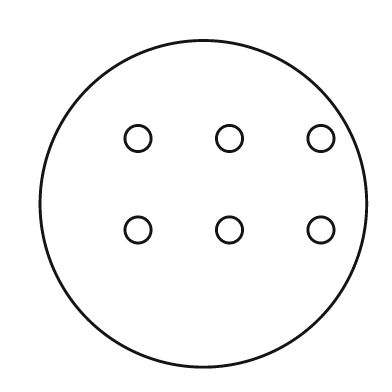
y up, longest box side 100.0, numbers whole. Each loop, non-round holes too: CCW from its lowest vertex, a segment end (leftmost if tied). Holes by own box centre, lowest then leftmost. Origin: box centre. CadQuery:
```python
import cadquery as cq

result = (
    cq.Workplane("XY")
    .moveTo(0.0, 0.0)
    .circle(50.0)
    .moveTo(-20.0, -8.0)
    .circle(4.0)
    .moveTo(8.0, -8.0)
    .circle(4.0)
    .moveTo(36.0, -8.0)
    .circle(4.0)
    .moveTo(-20.0, 20.0)
    .circle(4.0)
    .moveTo(8.0, 20.0)
    .circle(4.0)
    .moveTo(36.0, 20.0)
    .circle(4.0)
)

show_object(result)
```